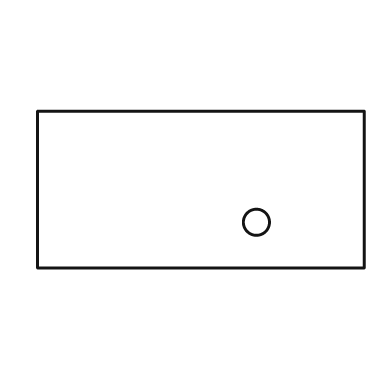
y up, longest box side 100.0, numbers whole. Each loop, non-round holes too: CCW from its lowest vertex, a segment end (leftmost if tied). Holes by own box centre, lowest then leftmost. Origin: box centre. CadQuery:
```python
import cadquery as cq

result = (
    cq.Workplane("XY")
    .moveTo(-50.0, -24.0)
    .lineTo(50.0, -24.0)
    .lineTo(50.0, 24.0)
    .lineTo(-50.0, 24.0)
    .close()
    .moveTo(17.0, -10.0)
    .circle(4.0)
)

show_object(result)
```